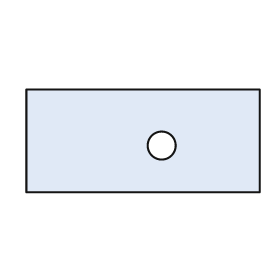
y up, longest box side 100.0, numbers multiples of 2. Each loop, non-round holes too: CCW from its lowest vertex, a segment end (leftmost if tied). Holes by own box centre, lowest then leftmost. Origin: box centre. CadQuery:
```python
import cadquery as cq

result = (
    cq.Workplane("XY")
    .moveTo(-50.0, -22.0)
    .lineTo(50.0, -22.0)
    .lineTo(50.0, 22.0)
    .lineTo(-50.0, 22.0)
    .close()
    .moveTo(8.0, -2.0)
    .circle(6.0)
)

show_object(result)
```